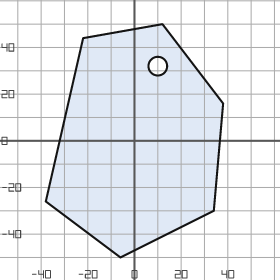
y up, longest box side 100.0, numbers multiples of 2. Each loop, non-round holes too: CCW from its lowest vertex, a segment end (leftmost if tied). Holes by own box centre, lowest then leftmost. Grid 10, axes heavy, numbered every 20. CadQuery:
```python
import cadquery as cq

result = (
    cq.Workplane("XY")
    .moveTo(-6.0, -50.0)
    .lineTo(34.0, -30.0)
    .lineTo(38.0, 16.0)
    .lineTo(12.0, 50.0)
    .lineTo(-22.0, 44.0)
    .lineTo(-38.0, -26.0)
    .close()
    .moveTo(10.0, 32.0)
    .circle(4.0)
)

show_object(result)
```